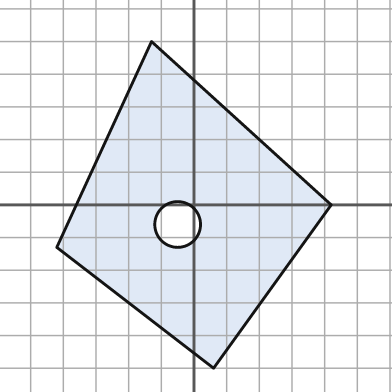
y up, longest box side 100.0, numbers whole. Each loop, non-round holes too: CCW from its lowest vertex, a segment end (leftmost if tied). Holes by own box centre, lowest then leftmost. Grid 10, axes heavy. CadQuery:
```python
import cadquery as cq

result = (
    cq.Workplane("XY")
    .moveTo(6.0, -50.0)
    .lineTo(42.0, 0.0)
    .lineTo(-13.0, 50.0)
    .lineTo(-42.0, -13.0)
    .close()
    .moveTo(-5.0, -6.0)
    .circle(7.0)
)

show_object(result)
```